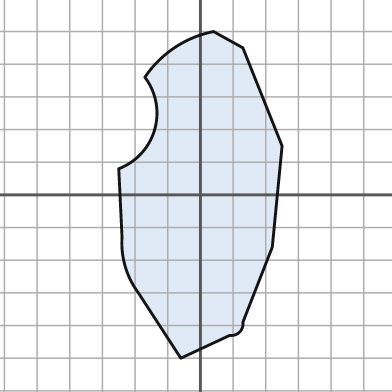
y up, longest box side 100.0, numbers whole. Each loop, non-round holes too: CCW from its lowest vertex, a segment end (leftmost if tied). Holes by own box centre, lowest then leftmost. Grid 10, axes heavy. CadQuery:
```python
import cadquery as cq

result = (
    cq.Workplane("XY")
    .moveTo(-6.0, -50.0)
    .lineTo(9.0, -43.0)
    .threePointArc((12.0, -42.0), (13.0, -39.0))
    .lineTo(22.0, -16.0)
    .lineTo(25.0, 15.0)
    .lineTo(13.0, 45.0)
    .lineTo(4.0, 50.0)
    .threePointArc((-8.0, 45.0), (-17.0, 36.0))
    .threePointArc((-14.0, 20.0), (-25.0, 8.0))
    .lineTo(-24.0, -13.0)
    .threePointArc((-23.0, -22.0), (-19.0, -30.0))
    .close()
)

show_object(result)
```